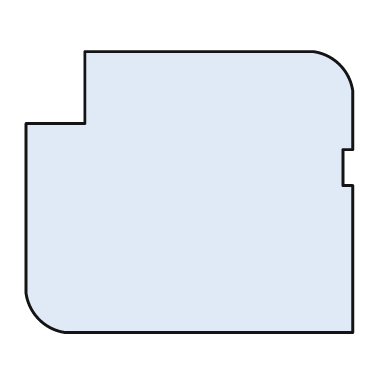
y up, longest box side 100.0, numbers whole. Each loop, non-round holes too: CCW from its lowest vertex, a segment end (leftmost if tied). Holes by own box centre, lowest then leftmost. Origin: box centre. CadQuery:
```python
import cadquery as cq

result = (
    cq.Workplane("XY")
    .moveTo(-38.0, -43.0)
    .lineTo(50.0, -43.0)
    .lineTo(50.0, 2.0)
    .lineTo(47.0, 2.0)
    .lineTo(47.0, 13.0)
    .lineTo(50.0, 13.0)
    .lineTo(50.0, 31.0)
    .threePointArc((46.0, 39.0), (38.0, 43.0))
    .lineTo(-32.0, 43.0)
    .lineTo(-32.0, 21.0)
    .lineTo(-50.0, 21.0)
    .lineTo(-50.0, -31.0)
    .threePointArc((-46.0, -39.0), (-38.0, -43.0))
    .close()
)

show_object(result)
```